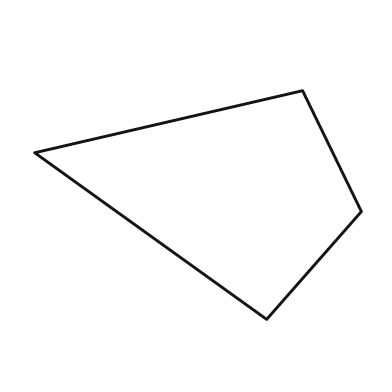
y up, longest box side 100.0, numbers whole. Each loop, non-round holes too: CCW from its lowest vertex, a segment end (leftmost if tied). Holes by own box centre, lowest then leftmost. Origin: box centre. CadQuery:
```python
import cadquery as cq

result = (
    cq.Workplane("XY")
    .moveTo(21.0, -35.0)
    .lineTo(50.0, -2.0)
    .lineTo(32.0, 35.0)
    .lineTo(-50.0, 16.0)
    .close()
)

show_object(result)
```